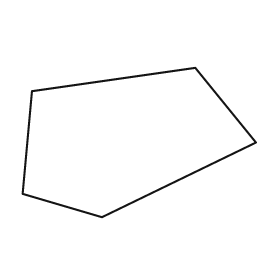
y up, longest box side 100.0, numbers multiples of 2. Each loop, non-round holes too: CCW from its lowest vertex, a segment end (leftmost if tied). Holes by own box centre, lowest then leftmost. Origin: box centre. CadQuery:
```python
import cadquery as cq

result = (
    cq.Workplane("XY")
    .moveTo(-16.0, -32.0)
    .lineTo(50.0, 0.0)
    .lineTo(24.0, 32.0)
    .lineTo(-46.0, 22.0)
    .lineTo(-50.0, -22.0)
    .close()
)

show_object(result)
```